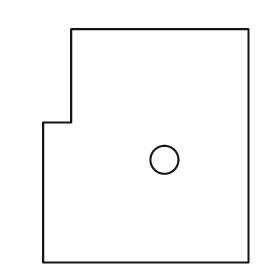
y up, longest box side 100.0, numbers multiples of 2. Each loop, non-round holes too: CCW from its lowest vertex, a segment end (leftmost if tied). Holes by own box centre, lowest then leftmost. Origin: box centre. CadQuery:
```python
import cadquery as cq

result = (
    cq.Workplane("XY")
    .moveTo(-44.0, -50.0)
    .lineTo(44.0, -50.0)
    .lineTo(44.0, 50.0)
    .lineTo(-32.0, 50.0)
    .lineTo(-32.0, 10.0)
    .lineTo(-44.0, 10.0)
    .close()
    .moveTo(8.0, -6.0)
    .circle(6.0)
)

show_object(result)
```